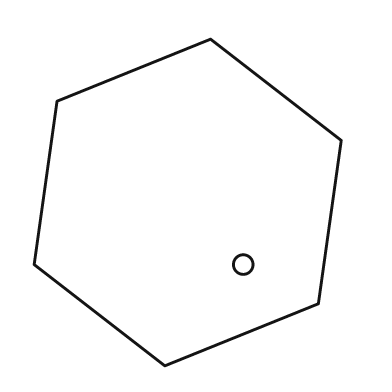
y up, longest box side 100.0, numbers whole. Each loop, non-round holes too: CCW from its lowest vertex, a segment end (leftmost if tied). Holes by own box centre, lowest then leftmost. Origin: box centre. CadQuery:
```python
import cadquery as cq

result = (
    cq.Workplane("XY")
    .moveTo(-7.0, -50.0)
    .lineTo(40.0, -31.0)
    .lineTo(47.0, 19.0)
    .lineTo(7.0, 50.0)
    .lineTo(-40.0, 31.0)
    .lineTo(-47.0, -19.0)
    .close()
    .moveTo(17.0, -19.0)
    .circle(3.0)
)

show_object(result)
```